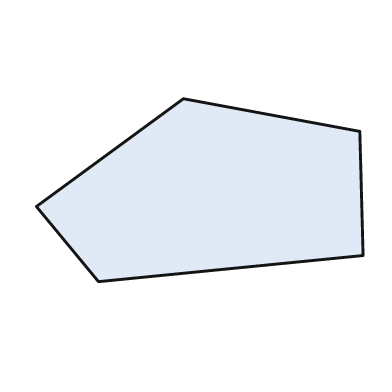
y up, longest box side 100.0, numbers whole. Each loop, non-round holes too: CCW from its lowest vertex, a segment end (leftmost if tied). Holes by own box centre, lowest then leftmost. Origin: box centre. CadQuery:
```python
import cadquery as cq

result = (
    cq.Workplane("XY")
    .moveTo(-31.0, -28.0)
    .lineTo(50.0, -20.0)
    .lineTo(49.0, 18.0)
    .lineTo(-5.0, 28.0)
    .lineTo(-50.0, -5.0)
    .close()
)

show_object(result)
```